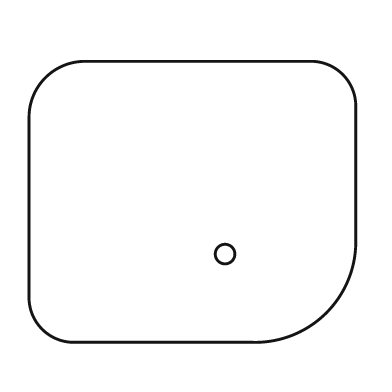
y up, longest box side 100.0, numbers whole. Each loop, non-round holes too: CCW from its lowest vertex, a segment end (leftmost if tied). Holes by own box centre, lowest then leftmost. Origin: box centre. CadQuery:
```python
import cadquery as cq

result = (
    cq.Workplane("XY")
    .moveTo(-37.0, -43.0)
    .lineTo(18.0, -43.0)
    .threePointArc((41.0, -34.0), (50.0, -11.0))
    .lineTo(50.0, 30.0)
    .threePointArc((46.0, 39.0), (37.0, 43.0))
    .lineTo(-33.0, 43.0)
    .threePointArc((-45.0, 38.0), (-50.0, 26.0))
    .lineTo(-50.0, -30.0)
    .threePointArc((-46.0, -39.0), (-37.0, -43.0))
    .close()
    .moveTo(10.0, -16.0)
    .circle(3.0)
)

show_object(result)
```